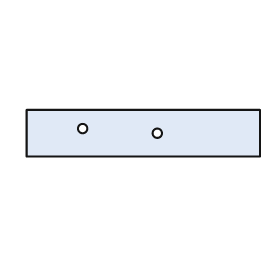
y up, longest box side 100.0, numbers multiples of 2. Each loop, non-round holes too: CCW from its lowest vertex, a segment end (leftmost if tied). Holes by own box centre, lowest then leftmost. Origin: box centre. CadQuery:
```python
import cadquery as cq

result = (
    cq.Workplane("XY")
    .moveTo(-50.0, -10.0)
    .lineTo(50.0, -10.0)
    .lineTo(50.0, 10.0)
    .lineTo(-50.0, 10.0)
    .close()
    .moveTo(6.0, 0.0)
    .circle(2.0)
    .moveTo(-26.0, 2.0)
    .circle(2.0)
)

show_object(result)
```